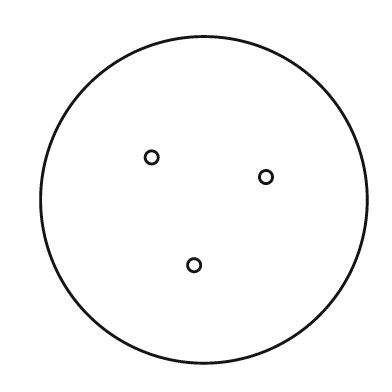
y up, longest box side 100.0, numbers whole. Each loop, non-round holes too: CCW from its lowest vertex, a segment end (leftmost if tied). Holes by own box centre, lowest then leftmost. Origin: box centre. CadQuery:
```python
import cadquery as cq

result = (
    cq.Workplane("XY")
    .moveTo(0.0, 0.0)
    .circle(50.0)
    .moveTo(-3.0, -20.0)
    .circle(2.0)
    .moveTo(19.0, 7.0)
    .circle(2.0)
    .moveTo(-16.0, 13.0)
    .circle(2.0)
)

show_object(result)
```